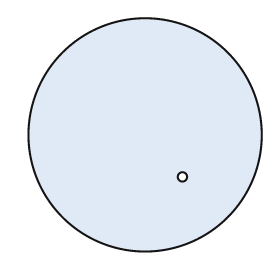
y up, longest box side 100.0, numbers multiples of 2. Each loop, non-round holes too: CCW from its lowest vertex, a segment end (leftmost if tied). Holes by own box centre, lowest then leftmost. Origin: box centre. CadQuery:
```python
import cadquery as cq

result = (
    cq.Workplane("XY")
    .moveTo(0.0, 0.0)
    .circle(50.0)
    .moveTo(16.0, -18.0)
    .circle(2.0)
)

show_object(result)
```